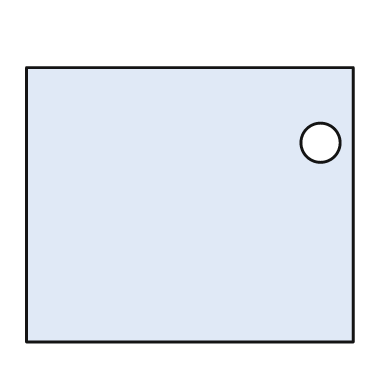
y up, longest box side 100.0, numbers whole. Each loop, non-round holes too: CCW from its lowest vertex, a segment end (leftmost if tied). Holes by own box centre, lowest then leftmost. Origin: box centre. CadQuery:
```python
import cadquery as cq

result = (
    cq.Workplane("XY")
    .moveTo(-50.0, -42.0)
    .lineTo(50.0, -42.0)
    .lineTo(50.0, 42.0)
    .lineTo(-50.0, 42.0)
    .close()
    .moveTo(40.0, 19.0)
    .circle(6.0)
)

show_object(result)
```